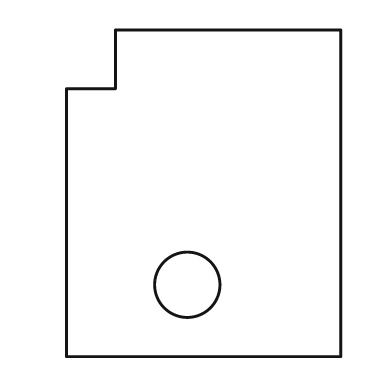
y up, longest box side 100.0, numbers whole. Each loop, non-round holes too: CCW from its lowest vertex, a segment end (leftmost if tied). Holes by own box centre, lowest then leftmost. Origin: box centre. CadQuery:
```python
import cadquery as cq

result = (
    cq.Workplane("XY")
    .moveTo(-42.0, -50.0)
    .lineTo(42.0, -50.0)
    .lineTo(42.0, 50.0)
    .lineTo(-27.0, 50.0)
    .lineTo(-27.0, 32.0)
    .lineTo(-42.0, 32.0)
    .close()
    .moveTo(-5.0, -28.0)
    .circle(10.0)
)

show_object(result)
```